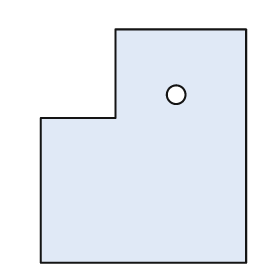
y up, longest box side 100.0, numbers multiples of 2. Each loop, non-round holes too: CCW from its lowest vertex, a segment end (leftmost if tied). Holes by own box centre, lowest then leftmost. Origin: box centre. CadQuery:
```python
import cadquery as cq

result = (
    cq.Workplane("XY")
    .moveTo(-44.0, -50.0)
    .lineTo(44.0, -50.0)
    .lineTo(44.0, 50.0)
    .lineTo(-12.0, 50.0)
    .lineTo(-12.0, 12.0)
    .lineTo(-44.0, 12.0)
    .close()
    .moveTo(14.0, 22.0)
    .circle(4.0)
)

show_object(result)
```